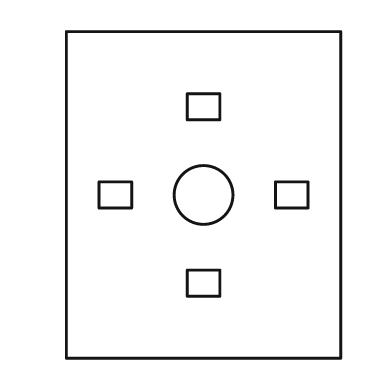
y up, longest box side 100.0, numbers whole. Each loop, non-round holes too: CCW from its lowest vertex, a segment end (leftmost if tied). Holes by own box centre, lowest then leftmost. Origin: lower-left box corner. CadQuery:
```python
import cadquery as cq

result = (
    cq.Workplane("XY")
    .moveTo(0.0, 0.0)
    .lineTo(84.0, 0.0)
    .lineTo(84.0, 100.0)
    .lineTo(0.0, 100.0)
    .close()
    .moveTo(37.0, 19.0)
    .lineTo(47.0, 19.0)
    .lineTo(47.0, 27.0)
    .lineTo(37.0, 27.0)
    .close()
    .moveTo(10.0, 46.0)
    .lineTo(20.0, 46.0)
    .lineTo(20.0, 54.0)
    .lineTo(10.0, 54.0)
    .close()
    .moveTo(42.0, 50.0)
    .circle(9.0)
    .moveTo(64.0, 46.0)
    .lineTo(74.0, 46.0)
    .lineTo(74.0, 54.0)
    .lineTo(64.0, 54.0)
    .close()
    .moveTo(37.0, 73.0)
    .lineTo(47.0, 73.0)
    .lineTo(47.0, 81.0)
    .lineTo(37.0, 81.0)
    .close()
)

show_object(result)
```